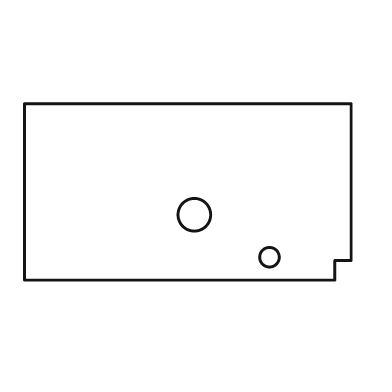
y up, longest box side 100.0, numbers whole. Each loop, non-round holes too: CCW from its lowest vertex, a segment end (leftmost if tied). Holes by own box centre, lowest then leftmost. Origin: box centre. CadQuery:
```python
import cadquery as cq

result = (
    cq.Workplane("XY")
    .moveTo(-50.0, -27.0)
    .lineTo(45.0, -27.0)
    .lineTo(45.0, -21.0)
    .lineTo(50.0, -21.0)
    .lineTo(50.0, 27.0)
    .lineTo(-50.0, 27.0)
    .close()
    .moveTo(25.0, -20.0)
    .circle(3.0)
    .moveTo(2.0, -7.0)
    .circle(5.0)
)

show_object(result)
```